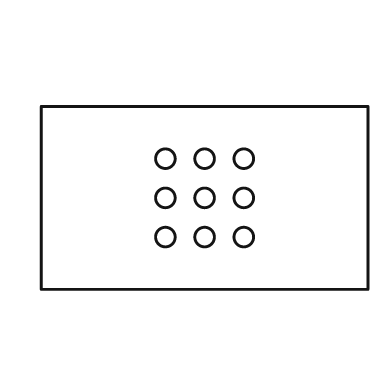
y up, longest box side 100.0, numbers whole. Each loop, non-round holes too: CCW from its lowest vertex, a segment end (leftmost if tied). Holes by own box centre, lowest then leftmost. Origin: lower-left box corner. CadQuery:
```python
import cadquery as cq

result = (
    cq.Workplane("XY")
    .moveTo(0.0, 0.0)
    .lineTo(100.0, 0.0)
    .lineTo(100.0, 56.0)
    .lineTo(0.0, 56.0)
    .close()
    .moveTo(38.0, 16.0)
    .circle(3.0)
    .moveTo(50.0, 16.0)
    .circle(3.0)
    .moveTo(62.0, 16.0)
    .circle(3.0)
    .moveTo(38.0, 28.0)
    .circle(3.0)
    .moveTo(50.0, 28.0)
    .circle(3.0)
    .moveTo(62.0, 28.0)
    .circle(3.0)
    .moveTo(38.0, 40.0)
    .circle(3.0)
    .moveTo(50.0, 40.0)
    .circle(3.0)
    .moveTo(62.0, 40.0)
    .circle(3.0)
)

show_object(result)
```